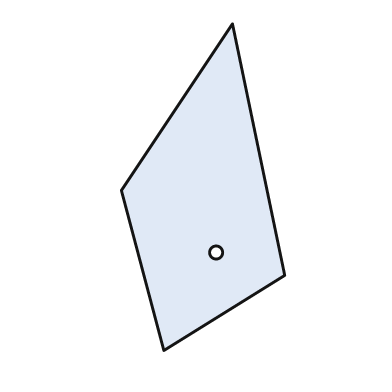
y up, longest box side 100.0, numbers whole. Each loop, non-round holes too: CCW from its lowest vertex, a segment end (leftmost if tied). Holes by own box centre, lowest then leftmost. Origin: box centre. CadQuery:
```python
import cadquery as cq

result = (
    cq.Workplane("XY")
    .moveTo(-12.0, -50.0)
    .lineTo(25.0, -27.0)
    .lineTo(9.0, 50.0)
    .lineTo(-25.0, -1.0)
    .close()
    .moveTo(4.0, -20.0)
    .circle(2.0)
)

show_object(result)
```